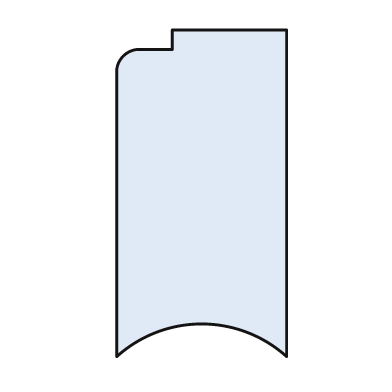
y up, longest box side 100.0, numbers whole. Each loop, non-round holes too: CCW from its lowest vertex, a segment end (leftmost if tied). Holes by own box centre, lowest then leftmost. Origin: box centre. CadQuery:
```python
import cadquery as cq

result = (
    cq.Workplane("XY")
    .moveTo(-26.0, -50.0)
    .threePointArc((0.0, -40.0), (26.0, -50.0))
    .lineTo(26.0, 50.0)
    .lineTo(-9.0, 50.0)
    .lineTo(-9.0, 44.0)
    .lineTo(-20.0, 44.0)
    .threePointArc((-24.0, 42.0), (-26.0, 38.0))
    .close()
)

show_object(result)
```